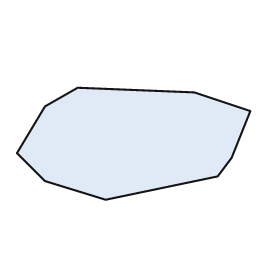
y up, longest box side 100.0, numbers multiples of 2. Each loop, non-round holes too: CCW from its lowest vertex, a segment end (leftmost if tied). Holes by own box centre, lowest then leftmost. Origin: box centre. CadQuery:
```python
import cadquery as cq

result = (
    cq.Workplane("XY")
    .moveTo(-12.0, -24.0)
    .lineTo(36.0, -14.0)
    .lineTo(42.0, -6.0)
    .lineTo(50.0, 14.0)
    .lineTo(26.0, 22.0)
    .lineTo(-24.0, 24.0)
    .lineTo(-38.0, 16.0)
    .lineTo(-50.0, -4.0)
    .lineTo(-38.0, -16.0)
    .close()
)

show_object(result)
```